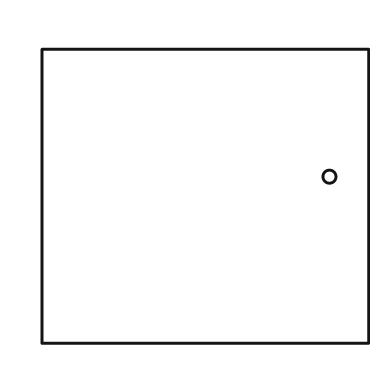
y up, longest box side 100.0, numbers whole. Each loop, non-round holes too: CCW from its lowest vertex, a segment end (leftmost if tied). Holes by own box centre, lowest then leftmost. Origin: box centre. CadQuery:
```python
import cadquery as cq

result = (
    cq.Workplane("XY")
    .moveTo(-50.0, -45.0)
    .lineTo(50.0, -45.0)
    .lineTo(50.0, 45.0)
    .lineTo(-50.0, 45.0)
    .close()
    .moveTo(38.0, 6.0)
    .circle(2.0)
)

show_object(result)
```